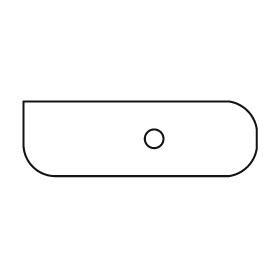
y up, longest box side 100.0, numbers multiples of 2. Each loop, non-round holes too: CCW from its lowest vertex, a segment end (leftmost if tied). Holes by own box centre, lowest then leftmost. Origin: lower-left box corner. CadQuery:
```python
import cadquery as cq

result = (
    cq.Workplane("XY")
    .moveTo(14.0, 0.0)
    .lineTo(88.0, 0.0)
    .threePointArc((96.0, 4.0), (100.0, 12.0))
    .lineTo(100.0, 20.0)
    .threePointArc((96.0, 28.0), (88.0, 32.0))
    .lineTo(0.0, 32.0)
    .lineTo(0.0, 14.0)
    .threePointArc((4.0, 4.0), (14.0, 0.0))
    .close()
    .moveTo(56.0, 16.0)
    .circle(4.0)
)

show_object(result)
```